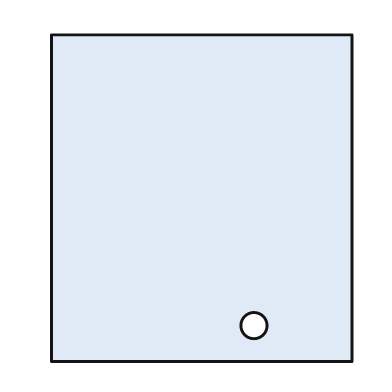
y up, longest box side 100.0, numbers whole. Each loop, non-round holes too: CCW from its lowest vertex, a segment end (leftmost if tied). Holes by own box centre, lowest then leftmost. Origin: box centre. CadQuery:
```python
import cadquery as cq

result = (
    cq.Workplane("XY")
    .moveTo(-46.0, -50.0)
    .lineTo(46.0, -50.0)
    .lineTo(46.0, 50.0)
    .lineTo(-46.0, 50.0)
    .close()
    .moveTo(16.0, -39.0)
    .circle(4.0)
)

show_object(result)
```